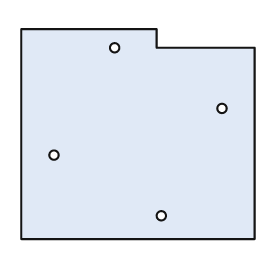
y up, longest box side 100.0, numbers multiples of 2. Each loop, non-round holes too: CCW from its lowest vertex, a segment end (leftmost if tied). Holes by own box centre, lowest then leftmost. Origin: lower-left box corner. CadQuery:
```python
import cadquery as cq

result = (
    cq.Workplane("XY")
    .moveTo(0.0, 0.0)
    .lineTo(100.0, 0.0)
    .lineTo(100.0, 82.0)
    .lineTo(58.0, 82.0)
    .lineTo(58.0, 90.0)
    .lineTo(0.0, 90.0)
    .close()
    .moveTo(60.0, 10.0)
    .circle(2.0)
    .moveTo(14.0, 36.0)
    .circle(2.0)
    .moveTo(86.0, 56.0)
    .circle(2.0)
    .moveTo(40.0, 82.0)
    .circle(2.0)
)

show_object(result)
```